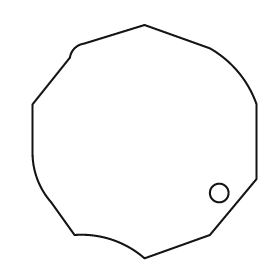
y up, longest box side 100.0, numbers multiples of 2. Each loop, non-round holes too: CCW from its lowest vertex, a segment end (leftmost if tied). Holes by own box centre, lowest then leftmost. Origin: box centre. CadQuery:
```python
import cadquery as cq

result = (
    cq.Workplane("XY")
    .moveTo(0.0, -50.0)
    .lineTo(28.0, -40.0)
    .lineTo(48.0, -16.0)
    .lineTo(48.0, 16.0)
    .threePointArc((40.0, 30.0), (28.0, 40.0))
    .lineTo(0.0, 50.0)
    .lineTo(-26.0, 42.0)
    .threePointArc((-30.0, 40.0), (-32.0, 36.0))
    .lineTo(-48.0, 16.0)
    .lineTo(-48.0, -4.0)
    .threePointArc((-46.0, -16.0), (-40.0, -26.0))
    .lineTo(-30.0, -40.0)
    .threePointArc((-14.0, -42.0), (0.0, -50.0))
    .close()
    .moveTo(32.0, -22.0)
    .circle(4.0)
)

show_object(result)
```